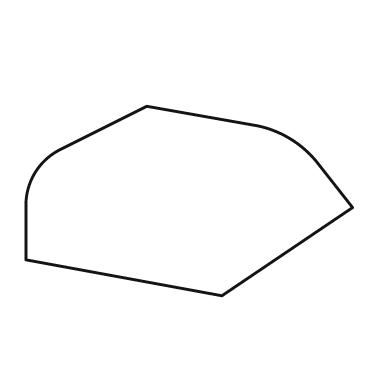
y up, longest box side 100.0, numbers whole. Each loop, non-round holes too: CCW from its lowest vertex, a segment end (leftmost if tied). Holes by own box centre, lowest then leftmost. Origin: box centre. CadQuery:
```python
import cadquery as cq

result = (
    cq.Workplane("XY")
    .moveTo(10.0, -29.0)
    .lineTo(50.0, -2.0)
    .lineTo(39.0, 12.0)
    .threePointArc((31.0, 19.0), (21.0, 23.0))
    .lineTo(-13.0, 29.0)
    .lineTo(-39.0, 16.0)
    .threePointArc((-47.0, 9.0), (-50.0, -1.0))
    .lineTo(-50.0, -18.0)
    .close()
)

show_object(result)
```